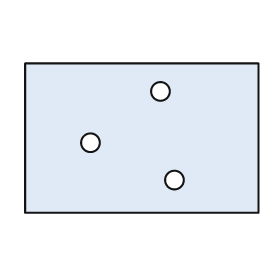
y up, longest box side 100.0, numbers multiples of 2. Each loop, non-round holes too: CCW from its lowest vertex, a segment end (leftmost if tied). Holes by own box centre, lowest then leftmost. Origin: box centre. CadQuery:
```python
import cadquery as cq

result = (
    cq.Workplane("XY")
    .moveTo(-50.0, -32.0)
    .lineTo(50.0, -32.0)
    .lineTo(50.0, 32.0)
    .lineTo(-50.0, 32.0)
    .close()
    .moveTo(14.0, -18.0)
    .circle(4.0)
    .moveTo(-22.0, -2.0)
    .circle(4.0)
    .moveTo(8.0, 20.0)
    .circle(4.0)
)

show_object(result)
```